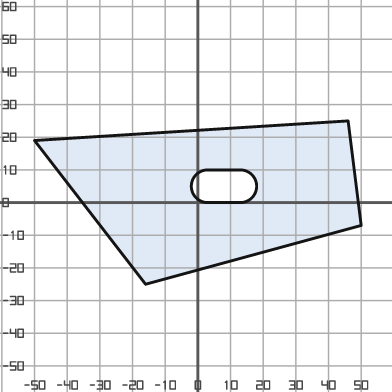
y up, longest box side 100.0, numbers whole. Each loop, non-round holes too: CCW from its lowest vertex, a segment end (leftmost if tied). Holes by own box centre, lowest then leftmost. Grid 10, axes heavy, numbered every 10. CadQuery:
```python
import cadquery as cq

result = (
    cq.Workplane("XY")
    .moveTo(-16.0, -25.0)
    .lineTo(50.0, -7.0)
    .lineTo(46.0, 25.0)
    .lineTo(-50.0, 19.0)
    .close()
    .moveTo(3.0, 0.0)
    .lineTo(13.0, 0.0)
    .threePointArc((18.0, 5.0), (13.0, 10.0))
    .lineTo(3.0, 10.0)
    .threePointArc((-2.0, 5.0), (3.0, 0.0))
    .close()
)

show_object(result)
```